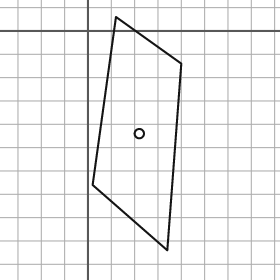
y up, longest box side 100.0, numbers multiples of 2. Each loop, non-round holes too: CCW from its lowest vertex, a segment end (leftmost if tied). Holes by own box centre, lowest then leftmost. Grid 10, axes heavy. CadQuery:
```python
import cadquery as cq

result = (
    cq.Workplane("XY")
    .moveTo(34.0, -94.0)
    .lineTo(40.0, -14.0)
    .lineTo(12.0, 6.0)
    .lineTo(2.0, -66.0)
    .close()
    .moveTo(22.0, -44.0)
    .circle(2.0)
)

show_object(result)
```